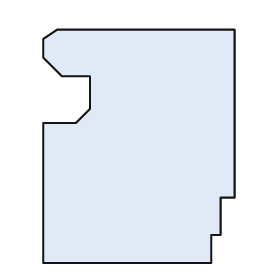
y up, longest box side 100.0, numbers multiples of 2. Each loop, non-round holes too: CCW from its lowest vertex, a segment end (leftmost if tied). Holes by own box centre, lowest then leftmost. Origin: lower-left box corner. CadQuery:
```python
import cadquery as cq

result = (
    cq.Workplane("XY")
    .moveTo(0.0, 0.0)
    .lineTo(72.0, 0.0)
    .lineTo(72.0, 12.0)
    .lineTo(76.0, 12.0)
    .lineTo(76.0, 28.0)
    .lineTo(82.0, 28.0)
    .lineTo(82.0, 100.0)
    .lineTo(6.0, 100.0)
    .lineTo(0.0, 96.0)
    .lineTo(0.0, 88.0)
    .lineTo(8.0, 80.0)
    .lineTo(20.0, 80.0)
    .lineTo(20.0, 66.0)
    .lineTo(14.0, 60.0)
    .lineTo(0.0, 60.0)
    .close()
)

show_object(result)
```